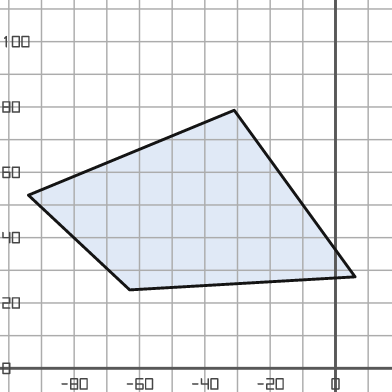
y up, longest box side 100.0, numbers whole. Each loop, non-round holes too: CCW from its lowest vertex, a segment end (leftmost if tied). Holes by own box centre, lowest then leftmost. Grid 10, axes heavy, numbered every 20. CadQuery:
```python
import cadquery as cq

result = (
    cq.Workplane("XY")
    .moveTo(-63.0, 24.0)
    .lineTo(6.0, 28.0)
    .lineTo(-31.0, 79.0)
    .lineTo(-94.0, 53.0)
    .close()
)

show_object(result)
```